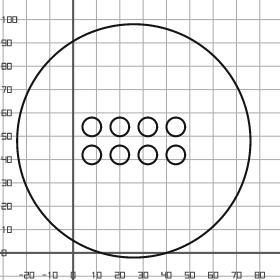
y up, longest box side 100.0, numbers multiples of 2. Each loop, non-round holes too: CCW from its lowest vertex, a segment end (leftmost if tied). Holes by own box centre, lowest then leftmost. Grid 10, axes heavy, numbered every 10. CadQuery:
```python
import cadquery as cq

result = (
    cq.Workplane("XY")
    .moveTo(26.0, 48.0)
    .circle(50.0)
    .moveTo(8.0, 42.0)
    .circle(4.0)
    .moveTo(20.0, 42.0)
    .circle(4.0)
    .moveTo(32.0, 42.0)
    .circle(4.0)
    .moveTo(44.0, 42.0)
    .circle(4.0)
    .moveTo(8.0, 54.0)
    .circle(4.0)
    .moveTo(20.0, 54.0)
    .circle(4.0)
    .moveTo(32.0, 54.0)
    .circle(4.0)
    .moveTo(44.0, 54.0)
    .circle(4.0)
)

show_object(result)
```